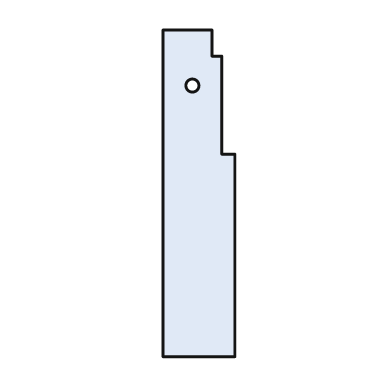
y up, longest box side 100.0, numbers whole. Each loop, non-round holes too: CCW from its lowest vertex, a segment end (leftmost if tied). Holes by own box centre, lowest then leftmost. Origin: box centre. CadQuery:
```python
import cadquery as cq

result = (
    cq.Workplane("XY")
    .moveTo(-11.0, -50.0)
    .lineTo(11.0, -50.0)
    .lineTo(11.0, 12.0)
    .lineTo(7.0, 12.0)
    .lineTo(7.0, 42.0)
    .lineTo(4.0, 42.0)
    .lineTo(4.0, 50.0)
    .lineTo(-11.0, 50.0)
    .close()
    .moveTo(-2.0, 33.0)
    .circle(2.0)
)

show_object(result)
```